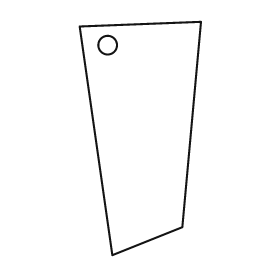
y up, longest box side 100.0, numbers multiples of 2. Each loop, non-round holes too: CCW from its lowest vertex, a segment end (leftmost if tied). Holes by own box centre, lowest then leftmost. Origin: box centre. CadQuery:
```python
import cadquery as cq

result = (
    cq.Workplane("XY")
    .moveTo(-12.0, -50.0)
    .lineTo(18.0, -38.0)
    .lineTo(26.0, 50.0)
    .lineTo(-26.0, 48.0)
    .close()
    .moveTo(-14.0, 40.0)
    .circle(4.0)
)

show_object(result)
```